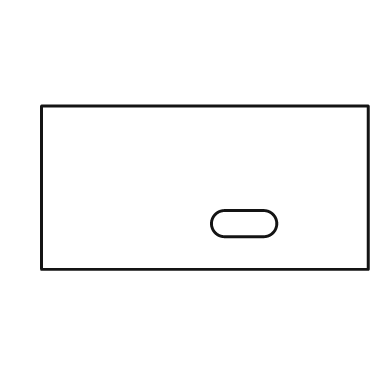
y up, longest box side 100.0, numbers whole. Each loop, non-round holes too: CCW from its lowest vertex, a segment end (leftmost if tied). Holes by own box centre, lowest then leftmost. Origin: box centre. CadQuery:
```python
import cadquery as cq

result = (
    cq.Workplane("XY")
    .moveTo(-50.0, -25.0)
    .lineTo(50.0, -25.0)
    .lineTo(50.0, 25.0)
    .lineTo(-50.0, 25.0)
    .close()
    .moveTo(6.0, -15.0)
    .lineTo(18.0, -15.0)
    .threePointArc((22.0, -11.0), (18.0, -7.0))
    .lineTo(6.0, -7.0)
    .threePointArc((2.0, -11.0), (6.0, -15.0))
    .close()
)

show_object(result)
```